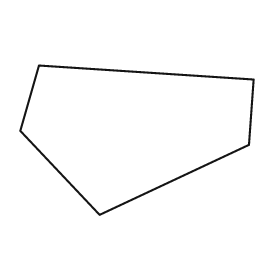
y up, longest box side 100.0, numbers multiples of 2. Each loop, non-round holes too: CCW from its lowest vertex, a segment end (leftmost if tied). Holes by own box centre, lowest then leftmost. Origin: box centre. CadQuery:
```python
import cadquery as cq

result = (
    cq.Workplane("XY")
    .moveTo(-16.0, -32.0)
    .lineTo(48.0, -2.0)
    .lineTo(50.0, 26.0)
    .lineTo(-42.0, 32.0)
    .lineTo(-50.0, 4.0)
    .close()
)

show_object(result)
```